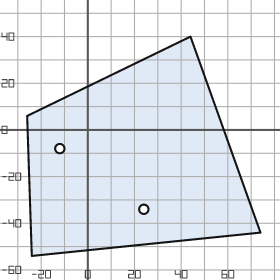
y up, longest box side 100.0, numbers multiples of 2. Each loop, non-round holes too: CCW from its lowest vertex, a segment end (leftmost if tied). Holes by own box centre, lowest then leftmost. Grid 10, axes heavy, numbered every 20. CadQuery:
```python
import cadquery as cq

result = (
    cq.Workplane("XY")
    .moveTo(-24.0, -54.0)
    .lineTo(74.0, -44.0)
    .lineTo(44.0, 40.0)
    .lineTo(-26.0, 6.0)
    .close()
    .moveTo(24.0, -34.0)
    .circle(2.0)
    .moveTo(-12.0, -8.0)
    .circle(2.0)
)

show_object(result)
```